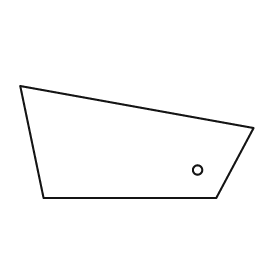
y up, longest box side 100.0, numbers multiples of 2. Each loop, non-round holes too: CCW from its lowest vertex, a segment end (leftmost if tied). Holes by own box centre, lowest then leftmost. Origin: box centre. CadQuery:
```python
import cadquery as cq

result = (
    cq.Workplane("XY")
    .moveTo(-40.0, -24.0)
    .lineTo(34.0, -24.0)
    .lineTo(50.0, 6.0)
    .lineTo(-50.0, 24.0)
    .close()
    .moveTo(26.0, -12.0)
    .circle(2.0)
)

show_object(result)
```